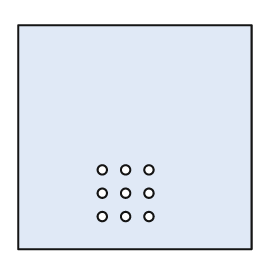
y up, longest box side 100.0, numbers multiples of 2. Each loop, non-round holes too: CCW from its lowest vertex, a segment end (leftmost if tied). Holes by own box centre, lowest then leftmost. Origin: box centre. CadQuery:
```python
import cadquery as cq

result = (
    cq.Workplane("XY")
    .moveTo(-50.0, -48.0)
    .lineTo(50.0, -48.0)
    .lineTo(50.0, 48.0)
    .lineTo(-50.0, 48.0)
    .close()
    .moveTo(-14.0, -34.0)
    .circle(2.0)
    .moveTo(-4.0, -34.0)
    .circle(2.0)
    .moveTo(6.0, -34.0)
    .circle(2.0)
    .moveTo(-14.0, -24.0)
    .circle(2.0)
    .moveTo(-4.0, -24.0)
    .circle(2.0)
    .moveTo(6.0, -24.0)
    .circle(2.0)
    .moveTo(-14.0, -14.0)
    .circle(2.0)
    .moveTo(-4.0, -14.0)
    .circle(2.0)
    .moveTo(6.0, -14.0)
    .circle(2.0)
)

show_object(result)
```